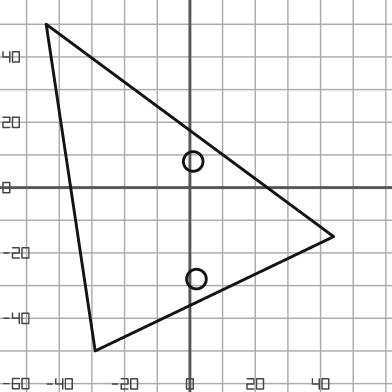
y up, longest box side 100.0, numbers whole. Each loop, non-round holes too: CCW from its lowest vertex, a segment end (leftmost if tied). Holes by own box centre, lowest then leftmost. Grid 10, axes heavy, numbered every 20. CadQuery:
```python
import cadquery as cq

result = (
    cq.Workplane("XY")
    .moveTo(-29.0, -50.0)
    .lineTo(44.0, -15.0)
    .lineTo(-44.0, 50.0)
    .close()
    .moveTo(2.0, -28.0)
    .circle(3.0)
    .moveTo(1.0, 8.0)
    .circle(3.0)
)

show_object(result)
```